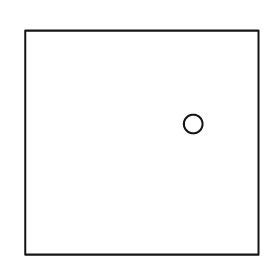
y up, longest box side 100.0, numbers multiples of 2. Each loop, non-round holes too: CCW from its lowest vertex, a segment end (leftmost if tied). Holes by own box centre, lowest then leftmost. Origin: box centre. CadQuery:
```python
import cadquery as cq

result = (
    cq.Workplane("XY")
    .moveTo(-50.0, -48.0)
    .lineTo(50.0, -48.0)
    .lineTo(50.0, 48.0)
    .lineTo(-50.0, 48.0)
    .close()
    .moveTo(22.0, 8.0)
    .circle(4.0)
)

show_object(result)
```